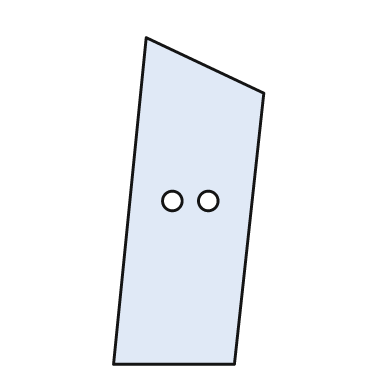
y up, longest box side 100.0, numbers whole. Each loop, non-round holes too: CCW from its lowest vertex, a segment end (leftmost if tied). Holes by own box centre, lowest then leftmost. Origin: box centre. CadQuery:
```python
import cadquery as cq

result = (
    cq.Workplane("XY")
    .moveTo(-23.0, -50.0)
    .lineTo(14.0, -50.0)
    .lineTo(23.0, 33.0)
    .lineTo(-13.0, 50.0)
    .close()
    .moveTo(-5.0, 0.0)
    .circle(3.0)
    .moveTo(6.0, 0.0)
    .circle(3.0)
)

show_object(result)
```